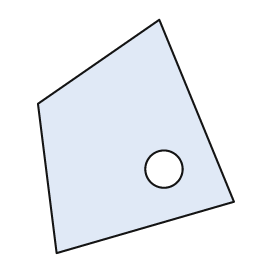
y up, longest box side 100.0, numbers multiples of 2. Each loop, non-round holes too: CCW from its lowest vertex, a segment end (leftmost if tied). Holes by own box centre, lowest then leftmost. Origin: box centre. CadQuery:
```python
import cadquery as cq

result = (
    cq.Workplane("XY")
    .moveTo(-34.0, -50.0)
    .lineTo(42.0, -28.0)
    .lineTo(10.0, 50.0)
    .lineTo(-42.0, 14.0)
    .close()
    .moveTo(12.0, -14.0)
    .circle(8.0)
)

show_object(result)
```